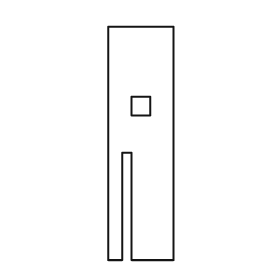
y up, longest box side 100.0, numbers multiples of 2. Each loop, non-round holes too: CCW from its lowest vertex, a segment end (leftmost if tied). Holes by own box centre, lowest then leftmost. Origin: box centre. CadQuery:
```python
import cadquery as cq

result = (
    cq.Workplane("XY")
    .moveTo(-14.0, -50.0)
    .lineTo(-8.0, -50.0)
    .lineTo(-8.0, -4.0)
    .lineTo(-4.0, -4.0)
    .lineTo(-4.0, -50.0)
    .lineTo(14.0, -50.0)
    .lineTo(14.0, 50.0)
    .lineTo(-14.0, 50.0)
    .close()
    .moveTo(-4.0, 12.0)
    .lineTo(4.0, 12.0)
    .lineTo(4.0, 20.0)
    .lineTo(-4.0, 20.0)
    .close()
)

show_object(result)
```